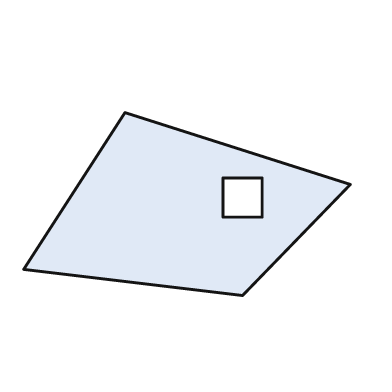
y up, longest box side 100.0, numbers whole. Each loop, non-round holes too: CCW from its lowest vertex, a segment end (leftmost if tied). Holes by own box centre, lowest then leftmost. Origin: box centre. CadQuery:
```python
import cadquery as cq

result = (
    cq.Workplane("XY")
    .moveTo(17.0, -28.0)
    .lineTo(50.0, 6.0)
    .lineTo(-19.0, 28.0)
    .lineTo(-50.0, -20.0)
    .close()
    .moveTo(11.0, -4.0)
    .lineTo(23.0, -4.0)
    .lineTo(23.0, 8.0)
    .lineTo(11.0, 8.0)
    .close()
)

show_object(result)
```